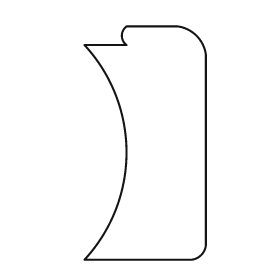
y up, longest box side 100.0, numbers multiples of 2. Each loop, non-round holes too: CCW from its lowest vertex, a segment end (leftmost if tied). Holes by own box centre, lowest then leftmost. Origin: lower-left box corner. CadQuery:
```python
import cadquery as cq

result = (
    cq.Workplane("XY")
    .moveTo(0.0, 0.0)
    .lineTo(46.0, 0.0)
    .threePointArc((50.0, 2.0), (52.0, 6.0))
    .lineTo(52.0, 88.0)
    .threePointArc((48.0, 96.0), (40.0, 100.0))
    .lineTo(18.0, 100.0)
    .threePointArc((16.0, 96.0), (18.0, 92.0))
    .lineTo(0.0, 92.0)
    .threePointArc((18.0, 46.0), (0.0, 0.0))
    .close()
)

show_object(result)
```